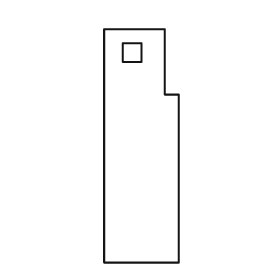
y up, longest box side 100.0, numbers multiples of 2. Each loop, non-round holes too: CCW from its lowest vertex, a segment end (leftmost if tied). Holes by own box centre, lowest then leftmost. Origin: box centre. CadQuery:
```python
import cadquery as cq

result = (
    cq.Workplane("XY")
    .moveTo(-16.0, -50.0)
    .lineTo(16.0, -50.0)
    .lineTo(16.0, 22.0)
    .lineTo(10.0, 22.0)
    .lineTo(10.0, 50.0)
    .lineTo(-16.0, 50.0)
    .close()
    .moveTo(-8.0, 36.0)
    .lineTo(0.0, 36.0)
    .lineTo(0.0, 44.0)
    .lineTo(-8.0, 44.0)
    .close()
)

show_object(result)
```